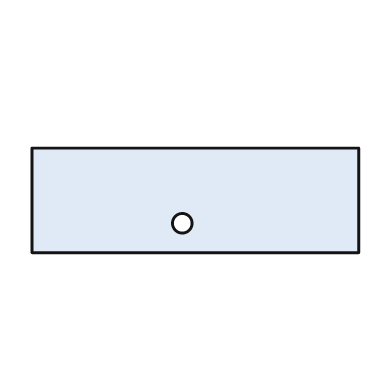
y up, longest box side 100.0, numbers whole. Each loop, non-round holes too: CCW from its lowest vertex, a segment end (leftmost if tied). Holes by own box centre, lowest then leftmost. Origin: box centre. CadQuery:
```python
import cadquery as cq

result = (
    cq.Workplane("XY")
    .moveTo(-50.0, -16.0)
    .lineTo(50.0, -16.0)
    .lineTo(50.0, 16.0)
    .lineTo(-50.0, 16.0)
    .close()
    .moveTo(-4.0, -7.0)
    .circle(3.0)
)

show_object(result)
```